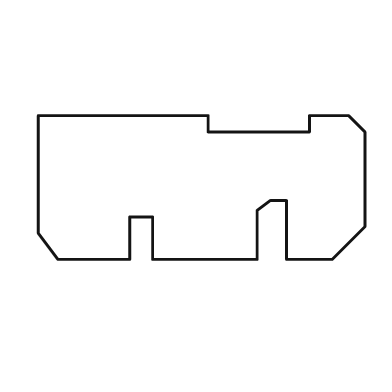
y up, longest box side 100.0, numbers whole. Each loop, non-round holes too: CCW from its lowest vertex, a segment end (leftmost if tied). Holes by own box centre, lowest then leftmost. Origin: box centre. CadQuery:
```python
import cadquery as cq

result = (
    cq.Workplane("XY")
    .moveTo(-44.0, -22.0)
    .lineTo(-22.0, -22.0)
    .lineTo(-22.0, -9.0)
    .lineTo(-15.0, -9.0)
    .lineTo(-15.0, -22.0)
    .lineTo(17.0, -22.0)
    .lineTo(17.0, -7.0)
    .lineTo(21.0, -4.0)
    .lineTo(26.0, -4.0)
    .lineTo(26.0, -22.0)
    .lineTo(40.0, -22.0)
    .lineTo(50.0, -12.0)
    .lineTo(50.0, 17.0)
    .lineTo(45.0, 22.0)
    .lineTo(33.0, 22.0)
    .lineTo(33.0, 17.0)
    .lineTo(2.0, 17.0)
    .lineTo(2.0, 22.0)
    .lineTo(-50.0, 22.0)
    .lineTo(-50.0, -14.0)
    .close()
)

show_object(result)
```